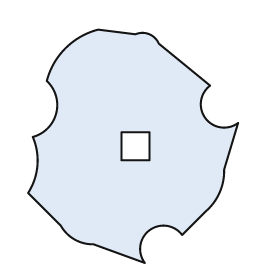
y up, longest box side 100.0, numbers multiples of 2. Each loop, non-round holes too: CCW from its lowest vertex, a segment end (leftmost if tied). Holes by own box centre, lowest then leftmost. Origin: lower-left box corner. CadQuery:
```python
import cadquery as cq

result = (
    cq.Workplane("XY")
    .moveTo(50.0, 0.0)
    .threePointArc((52.0, 14.0), (66.0, 12.0))
    .lineTo(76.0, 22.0)
    .threePointArc((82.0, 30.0), (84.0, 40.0))
    .lineTo(90.0, 60.0)
    .threePointArc((76.0, 62.0), (78.0, 76.0))
    .lineTo(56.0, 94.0)
    .threePointArc((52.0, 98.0), (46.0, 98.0))
    .lineTo(30.0, 100.0)
    .threePointArc((16.0, 92.0), (8.0, 78.0))
    .threePointArc((12.0, 64.0), (2.0, 54.0))
    .threePointArc((4.0, 42.0), (0.0, 30.0))
    .lineTo(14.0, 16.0)
    .threePointArc((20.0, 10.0), (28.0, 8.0))
    .close()
    .moveTo(40.0, 44.0)
    .lineTo(52.0, 44.0)
    .lineTo(52.0, 56.0)
    .lineTo(40.0, 56.0)
    .close()
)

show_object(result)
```